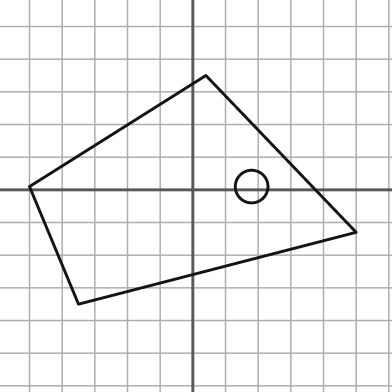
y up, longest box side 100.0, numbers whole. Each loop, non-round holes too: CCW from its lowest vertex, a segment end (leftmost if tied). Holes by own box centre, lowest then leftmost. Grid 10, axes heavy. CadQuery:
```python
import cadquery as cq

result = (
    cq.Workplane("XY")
    .moveTo(-35.0, -35.0)
    .lineTo(50.0, -13.0)
    .lineTo(4.0, 35.0)
    .lineTo(-50.0, 1.0)
    .close()
    .moveTo(18.0, 1.0)
    .circle(5.0)
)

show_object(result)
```